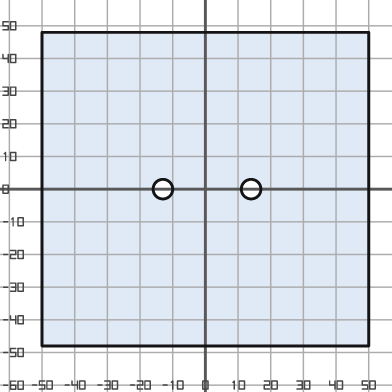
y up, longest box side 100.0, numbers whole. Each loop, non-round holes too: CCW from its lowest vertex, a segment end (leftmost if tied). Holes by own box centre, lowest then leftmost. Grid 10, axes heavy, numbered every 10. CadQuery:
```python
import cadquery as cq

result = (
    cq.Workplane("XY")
    .moveTo(-50.0, -48.0)
    .lineTo(50.0, -48.0)
    .lineTo(50.0, 48.0)
    .lineTo(-50.0, 48.0)
    .close()
    .moveTo(-13.0, 0.0)
    .circle(3.0)
    .moveTo(14.0, 0.0)
    .circle(3.0)
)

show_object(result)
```